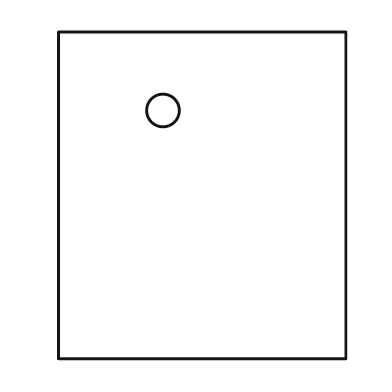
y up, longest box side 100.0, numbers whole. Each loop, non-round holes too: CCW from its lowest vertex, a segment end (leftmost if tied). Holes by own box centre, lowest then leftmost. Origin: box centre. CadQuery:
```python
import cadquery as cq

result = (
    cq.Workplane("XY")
    .moveTo(-44.0, -50.0)
    .lineTo(44.0, -50.0)
    .lineTo(44.0, 50.0)
    .lineTo(-44.0, 50.0)
    .close()
    .moveTo(-12.0, 26.0)
    .circle(5.0)
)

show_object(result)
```